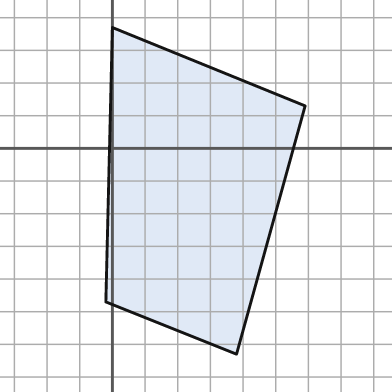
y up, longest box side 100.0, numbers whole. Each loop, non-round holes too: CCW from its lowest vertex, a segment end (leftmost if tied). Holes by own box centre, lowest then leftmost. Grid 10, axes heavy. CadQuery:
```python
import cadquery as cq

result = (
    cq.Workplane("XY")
    .moveTo(38.0, -63.0)
    .lineTo(59.0, 13.0)
    .lineTo(0.0, 37.0)
    .lineTo(-2.0, -47.0)
    .close()
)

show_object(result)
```